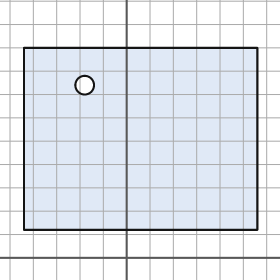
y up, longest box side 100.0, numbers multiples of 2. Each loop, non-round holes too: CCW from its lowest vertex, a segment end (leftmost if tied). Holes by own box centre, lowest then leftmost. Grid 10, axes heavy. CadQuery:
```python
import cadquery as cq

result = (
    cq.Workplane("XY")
    .moveTo(-44.0, 12.0)
    .lineTo(56.0, 12.0)
    .lineTo(56.0, 90.0)
    .lineTo(-44.0, 90.0)
    .close()
    .moveTo(-18.0, 74.0)
    .circle(4.0)
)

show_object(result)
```